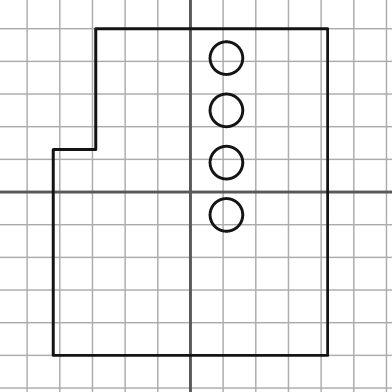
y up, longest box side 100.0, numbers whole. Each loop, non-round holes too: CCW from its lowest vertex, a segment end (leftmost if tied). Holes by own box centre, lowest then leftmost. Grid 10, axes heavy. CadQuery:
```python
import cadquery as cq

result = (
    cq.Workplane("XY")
    .moveTo(-42.0, -50.0)
    .lineTo(42.0, -50.0)
    .lineTo(42.0, 50.0)
    .lineTo(-29.0, 50.0)
    .lineTo(-29.0, 13.0)
    .lineTo(-42.0, 13.0)
    .close()
    .moveTo(11.0, -7.0)
    .circle(5.0)
    .moveTo(11.0, 9.0)
    .circle(5.0)
    .moveTo(11.0, 25.0)
    .circle(5.0)
    .moveTo(11.0, 41.0)
    .circle(5.0)
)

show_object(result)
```